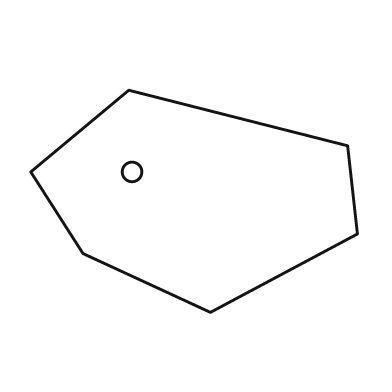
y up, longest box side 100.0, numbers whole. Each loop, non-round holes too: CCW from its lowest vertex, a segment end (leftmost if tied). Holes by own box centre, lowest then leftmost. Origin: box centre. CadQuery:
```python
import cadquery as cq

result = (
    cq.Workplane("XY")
    .moveTo(5.0, -34.0)
    .lineTo(50.0, -10.0)
    .lineTo(47.0, 17.0)
    .lineTo(-20.0, 34.0)
    .lineTo(-50.0, 9.0)
    .lineTo(-34.0, -16.0)
    .close()
    .moveTo(-19.0, 9.0)
    .circle(3.0)
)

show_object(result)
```